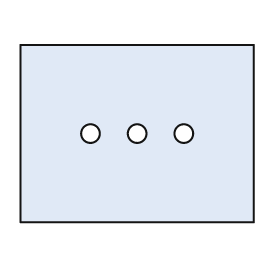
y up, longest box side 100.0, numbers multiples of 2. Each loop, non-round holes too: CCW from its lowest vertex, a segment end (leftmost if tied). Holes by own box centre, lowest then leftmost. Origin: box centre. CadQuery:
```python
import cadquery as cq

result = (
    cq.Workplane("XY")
    .moveTo(-50.0, -38.0)
    .lineTo(50.0, -38.0)
    .lineTo(50.0, 38.0)
    .lineTo(-50.0, 38.0)
    .close()
    .moveTo(-20.0, 0.0)
    .circle(4.0)
    .moveTo(0.0, 0.0)
    .circle(4.0)
    .moveTo(20.0, 0.0)
    .circle(4.0)
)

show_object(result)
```